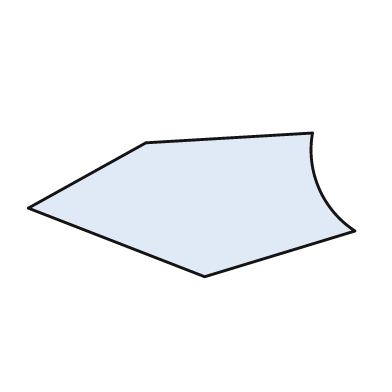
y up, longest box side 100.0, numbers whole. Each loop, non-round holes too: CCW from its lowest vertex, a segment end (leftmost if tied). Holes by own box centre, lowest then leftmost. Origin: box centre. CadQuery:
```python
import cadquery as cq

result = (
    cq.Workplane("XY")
    .moveTo(4.0, -22.0)
    .lineTo(50.0, -8.0)
    .threePointArc((39.0, 5.0), (37.0, 22.0))
    .lineTo(-14.0, 19.0)
    .lineTo(-50.0, -1.0)
    .close()
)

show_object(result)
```